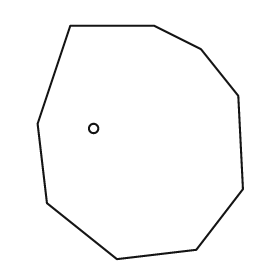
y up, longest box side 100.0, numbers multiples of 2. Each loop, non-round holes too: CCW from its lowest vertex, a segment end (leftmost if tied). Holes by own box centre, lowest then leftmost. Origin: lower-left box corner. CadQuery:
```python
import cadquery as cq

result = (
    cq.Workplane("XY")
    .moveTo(34.0, 0.0)
    .lineTo(68.0, 4.0)
    .lineTo(88.0, 30.0)
    .lineTo(86.0, 70.0)
    .lineTo(70.0, 90.0)
    .lineTo(50.0, 100.0)
    .lineTo(14.0, 100.0)
    .lineTo(0.0, 58.0)
    .lineTo(4.0, 24.0)
    .close()
    .moveTo(24.0, 56.0)
    .circle(2.0)
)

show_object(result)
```